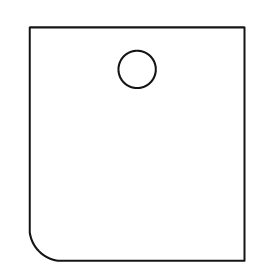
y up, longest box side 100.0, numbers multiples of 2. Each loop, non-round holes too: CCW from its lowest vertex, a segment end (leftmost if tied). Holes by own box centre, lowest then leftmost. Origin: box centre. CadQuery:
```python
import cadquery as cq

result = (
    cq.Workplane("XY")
    .moveTo(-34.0, -50.0)
    .lineTo(46.0, -50.0)
    .lineTo(46.0, 50.0)
    .lineTo(-46.0, 50.0)
    .lineTo(-46.0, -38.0)
    .threePointArc((-42.0, -46.0), (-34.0, -50.0))
    .close()
    .moveTo(0.0, 32.0)
    .circle(8.0)
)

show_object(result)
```